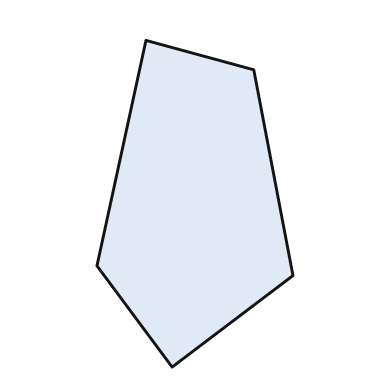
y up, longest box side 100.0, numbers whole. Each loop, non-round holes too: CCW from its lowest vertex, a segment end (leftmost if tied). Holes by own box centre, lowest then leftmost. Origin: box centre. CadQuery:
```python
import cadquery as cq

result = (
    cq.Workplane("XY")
    .moveTo(-7.0, -50.0)
    .lineTo(30.0, -22.0)
    .lineTo(18.0, 41.0)
    .lineTo(-15.0, 50.0)
    .lineTo(-30.0, -19.0)
    .close()
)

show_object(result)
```